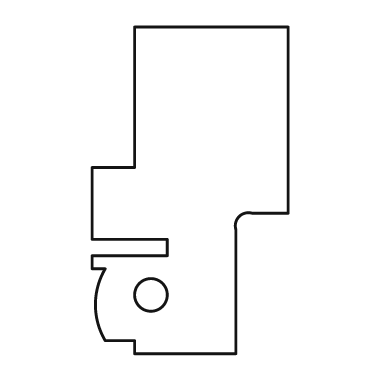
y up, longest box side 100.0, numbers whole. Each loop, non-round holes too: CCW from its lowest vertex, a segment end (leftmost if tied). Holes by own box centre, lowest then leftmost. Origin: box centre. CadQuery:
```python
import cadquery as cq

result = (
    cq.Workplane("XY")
    .moveTo(-17.0, -50.0)
    .lineTo(14.0, -50.0)
    .lineTo(14.0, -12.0)
    .threePointArc((15.0, -8.0), (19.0, -7.0))
    .lineTo(30.0, -7.0)
    .lineTo(30.0, 50.0)
    .lineTo(-17.0, 50.0)
    .lineTo(-17.0, 7.0)
    .lineTo(-30.0, 7.0)
    .lineTo(-30.0, -15.0)
    .lineTo(-7.0, -15.0)
    .lineTo(-7.0, -20.0)
    .lineTo(-30.0, -20.0)
    .lineTo(-30.0, -24.0)
    .lineTo(-26.0, -24.0)
    .threePointArc((-29.0, -35.0), (-26.0, -46.0))
    .lineTo(-17.0, -46.0)
    .close()
    .moveTo(-12.0, -32.0)
    .circle(5.0)
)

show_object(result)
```